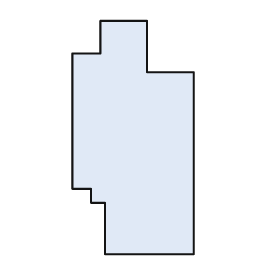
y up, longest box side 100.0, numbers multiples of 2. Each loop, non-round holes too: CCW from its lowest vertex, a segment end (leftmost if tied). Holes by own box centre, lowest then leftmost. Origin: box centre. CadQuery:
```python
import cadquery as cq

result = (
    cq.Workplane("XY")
    .moveTo(-12.0, -50.0)
    .lineTo(26.0, -50.0)
    .lineTo(26.0, 28.0)
    .lineTo(6.0, 28.0)
    .lineTo(6.0, 50.0)
    .lineTo(-14.0, 50.0)
    .lineTo(-14.0, 36.0)
    .lineTo(-26.0, 36.0)
    .lineTo(-26.0, -22.0)
    .lineTo(-18.0, -22.0)
    .lineTo(-18.0, -28.0)
    .lineTo(-12.0, -28.0)
    .close()
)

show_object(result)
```